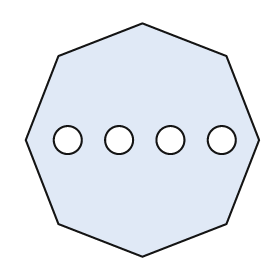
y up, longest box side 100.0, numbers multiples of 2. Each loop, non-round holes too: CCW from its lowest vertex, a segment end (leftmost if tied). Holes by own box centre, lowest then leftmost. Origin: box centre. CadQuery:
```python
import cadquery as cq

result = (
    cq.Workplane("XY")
    .moveTo(0.0, -50.0)
    .lineTo(36.0, -36.0)
    .lineTo(50.0, 0.0)
    .lineTo(36.0, 36.0)
    .lineTo(0.0, 50.0)
    .lineTo(-36.0, 36.0)
    .lineTo(-50.0, 0.0)
    .lineTo(-36.0, -36.0)
    .close()
    .moveTo(-32.0, 0.0)
    .circle(6.0)
    .moveTo(-10.0, 0.0)
    .circle(6.0)
    .moveTo(12.0, 0.0)
    .circle(6.0)
    .moveTo(34.0, 0.0)
    .circle(6.0)
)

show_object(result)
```